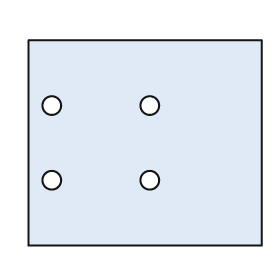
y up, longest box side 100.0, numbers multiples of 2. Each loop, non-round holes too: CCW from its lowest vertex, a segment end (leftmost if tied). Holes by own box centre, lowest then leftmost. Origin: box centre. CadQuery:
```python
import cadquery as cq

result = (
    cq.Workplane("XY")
    .moveTo(-50.0, -44.0)
    .lineTo(50.0, -44.0)
    .lineTo(50.0, 44.0)
    .lineTo(-50.0, 44.0)
    .close()
    .moveTo(-40.0, -16.0)
    .circle(4.0)
    .moveTo(2.0, -16.0)
    .circle(4.0)
    .moveTo(-40.0, 16.0)
    .circle(4.0)
    .moveTo(2.0, 16.0)
    .circle(4.0)
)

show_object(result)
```